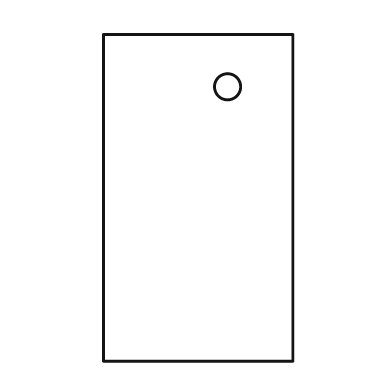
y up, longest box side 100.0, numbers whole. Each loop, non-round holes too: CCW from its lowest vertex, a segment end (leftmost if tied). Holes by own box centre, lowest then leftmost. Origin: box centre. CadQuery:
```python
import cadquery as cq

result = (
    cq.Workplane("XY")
    .moveTo(-29.0, -50.0)
    .lineTo(29.0, -50.0)
    .lineTo(29.0, 50.0)
    .lineTo(-29.0, 50.0)
    .close()
    .moveTo(9.0, 34.0)
    .circle(4.0)
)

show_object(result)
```